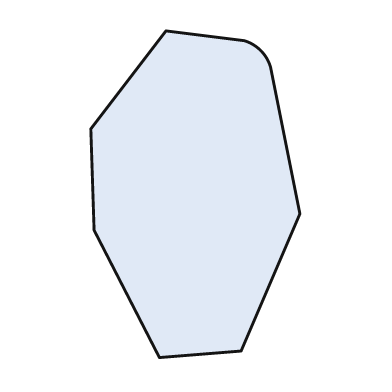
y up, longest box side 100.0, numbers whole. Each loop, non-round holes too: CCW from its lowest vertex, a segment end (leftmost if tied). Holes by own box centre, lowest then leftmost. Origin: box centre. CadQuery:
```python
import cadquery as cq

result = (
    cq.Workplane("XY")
    .moveTo(-11.0, -50.0)
    .lineTo(14.0, -48.0)
    .lineTo(32.0, -6.0)
    .lineTo(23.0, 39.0)
    .threePointArc((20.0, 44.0), (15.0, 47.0))
    .lineTo(-9.0, 50.0)
    .lineTo(-32.0, 20.0)
    .lineTo(-31.0, -11.0)
    .close()
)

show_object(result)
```